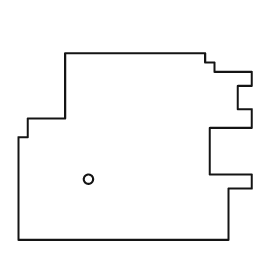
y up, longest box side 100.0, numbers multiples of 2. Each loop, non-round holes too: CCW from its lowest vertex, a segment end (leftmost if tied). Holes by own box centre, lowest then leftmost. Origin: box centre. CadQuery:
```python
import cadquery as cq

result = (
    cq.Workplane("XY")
    .moveTo(-50.0, -40.0)
    .lineTo(40.0, -40.0)
    .lineTo(40.0, -18.0)
    .lineTo(50.0, -18.0)
    .lineTo(50.0, -12.0)
    .lineTo(32.0, -12.0)
    .lineTo(32.0, 8.0)
    .lineTo(50.0, 8.0)
    .lineTo(50.0, 16.0)
    .lineTo(44.0, 16.0)
    .lineTo(44.0, 26.0)
    .lineTo(50.0, 26.0)
    .lineTo(50.0, 32.0)
    .lineTo(34.0, 32.0)
    .lineTo(34.0, 36.0)
    .lineTo(30.0, 36.0)
    .lineTo(30.0, 40.0)
    .lineTo(-30.0, 40.0)
    .lineTo(-30.0, 12.0)
    .lineTo(-46.0, 12.0)
    .lineTo(-46.0, 4.0)
    .lineTo(-50.0, 4.0)
    .close()
    .moveTo(-20.0, -14.0)
    .circle(2.0)
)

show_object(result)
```